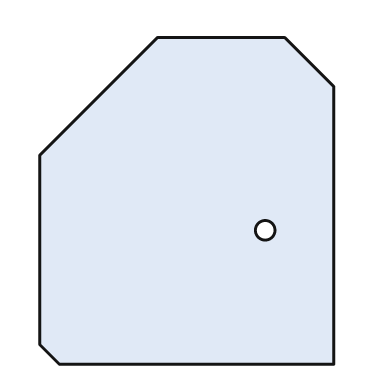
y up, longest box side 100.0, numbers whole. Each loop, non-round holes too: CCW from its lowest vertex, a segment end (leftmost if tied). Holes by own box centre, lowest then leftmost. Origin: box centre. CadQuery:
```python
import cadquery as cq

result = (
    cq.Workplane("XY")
    .moveTo(-39.0, -50.0)
    .lineTo(45.0, -50.0)
    .lineTo(45.0, 35.0)
    .lineTo(30.0, 50.0)
    .lineTo(-9.0, 50.0)
    .lineTo(-45.0, 14.0)
    .lineTo(-45.0, -44.0)
    .close()
    .moveTo(24.0, -9.0)
    .circle(3.0)
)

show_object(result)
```